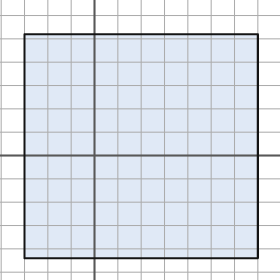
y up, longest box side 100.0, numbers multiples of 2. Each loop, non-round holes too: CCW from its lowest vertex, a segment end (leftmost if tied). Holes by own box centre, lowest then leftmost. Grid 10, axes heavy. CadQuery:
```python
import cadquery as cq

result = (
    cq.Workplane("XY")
    .moveTo(-30.0, -44.0)
    .lineTo(70.0, -44.0)
    .lineTo(70.0, 52.0)
    .lineTo(-30.0, 52.0)
    .close()
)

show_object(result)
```